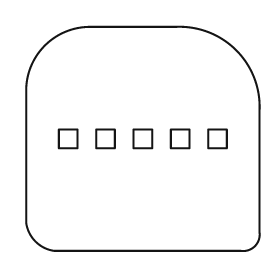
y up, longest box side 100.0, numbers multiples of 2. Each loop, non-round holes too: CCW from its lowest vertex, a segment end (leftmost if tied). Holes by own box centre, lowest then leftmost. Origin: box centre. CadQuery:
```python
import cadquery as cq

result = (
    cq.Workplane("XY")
    .moveTo(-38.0, -48.0)
    .lineTo(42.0, -48.0)
    .threePointArc((48.0, -46.0), (50.0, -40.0))
    .lineTo(50.0, 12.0)
    .threePointArc((40.0, 38.0), (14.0, 48.0))
    .lineTo(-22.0, 48.0)
    .threePointArc((-42.0, 40.0), (-50.0, 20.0))
    .lineTo(-50.0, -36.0)
    .threePointArc((-46.0, -44.0), (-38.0, -48.0))
    .close()
    .moveTo(-36.0, -4.0)
    .lineTo(-28.0, -4.0)
    .lineTo(-28.0, 4.0)
    .lineTo(-36.0, 4.0)
    .close()
    .moveTo(-20.0, -4.0)
    .lineTo(-12.0, -4.0)
    .lineTo(-12.0, 4.0)
    .lineTo(-20.0, 4.0)
    .close()
    .moveTo(-4.0, -4.0)
    .lineTo(4.0, -4.0)
    .lineTo(4.0, 4.0)
    .lineTo(-4.0, 4.0)
    .close()
    .moveTo(12.0, -4.0)
    .lineTo(20.0, -4.0)
    .lineTo(20.0, 4.0)
    .lineTo(12.0, 4.0)
    .close()
    .moveTo(28.0, -4.0)
    .lineTo(36.0, -4.0)
    .lineTo(36.0, 4.0)
    .lineTo(28.0, 4.0)
    .close()
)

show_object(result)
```